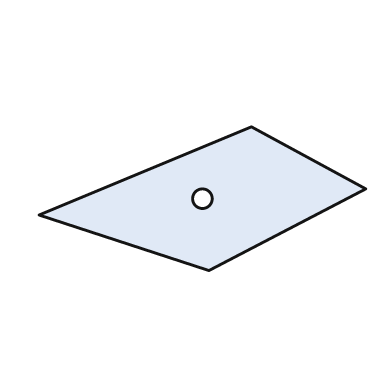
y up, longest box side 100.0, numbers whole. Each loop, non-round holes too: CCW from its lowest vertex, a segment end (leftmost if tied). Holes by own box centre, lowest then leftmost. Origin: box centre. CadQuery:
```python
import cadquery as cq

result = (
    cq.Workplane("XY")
    .moveTo(2.0, -22.0)
    .lineTo(50.0, 3.0)
    .lineTo(15.0, 22.0)
    .lineTo(-50.0, -5.0)
    .close()
    .moveTo(0.0, 0.0)
    .circle(3.0)
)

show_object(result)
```